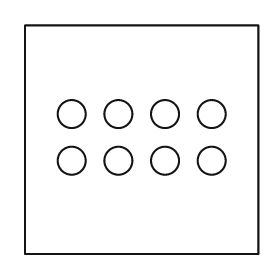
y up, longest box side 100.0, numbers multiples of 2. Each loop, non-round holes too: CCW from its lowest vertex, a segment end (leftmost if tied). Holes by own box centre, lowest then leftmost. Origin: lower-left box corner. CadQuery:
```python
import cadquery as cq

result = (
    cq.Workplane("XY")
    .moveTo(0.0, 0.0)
    .lineTo(100.0, 0.0)
    .lineTo(100.0, 98.0)
    .lineTo(0.0, 98.0)
    .close()
    .moveTo(20.0, 40.0)
    .circle(6.0)
    .moveTo(40.0, 40.0)
    .circle(6.0)
    .moveTo(60.0, 40.0)
    .circle(6.0)
    .moveTo(80.0, 40.0)
    .circle(6.0)
    .moveTo(20.0, 60.0)
    .circle(6.0)
    .moveTo(40.0, 60.0)
    .circle(6.0)
    .moveTo(60.0, 60.0)
    .circle(6.0)
    .moveTo(80.0, 60.0)
    .circle(6.0)
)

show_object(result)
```